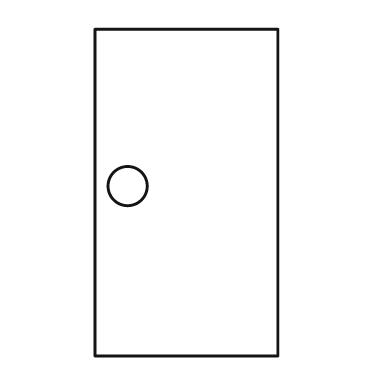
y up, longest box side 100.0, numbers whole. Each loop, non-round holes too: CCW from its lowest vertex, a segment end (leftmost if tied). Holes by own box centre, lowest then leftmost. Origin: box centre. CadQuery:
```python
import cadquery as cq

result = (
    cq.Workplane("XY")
    .moveTo(-28.0, -50.0)
    .lineTo(28.0, -50.0)
    .lineTo(28.0, 50.0)
    .lineTo(-28.0, 50.0)
    .close()
    .moveTo(-18.0, 2.0)
    .circle(6.0)
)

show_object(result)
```